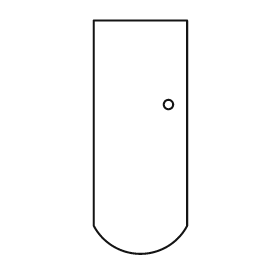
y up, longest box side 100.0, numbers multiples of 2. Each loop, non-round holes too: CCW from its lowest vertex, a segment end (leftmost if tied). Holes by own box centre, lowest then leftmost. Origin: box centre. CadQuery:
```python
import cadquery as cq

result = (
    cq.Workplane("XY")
    .moveTo(-20.0, -38.0)
    .threePointArc((0.0, -50.0), (20.0, -38.0))
    .lineTo(20.0, 50.0)
    .lineTo(-20.0, 50.0)
    .close()
    .moveTo(12.0, 14.0)
    .circle(2.0)
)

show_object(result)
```